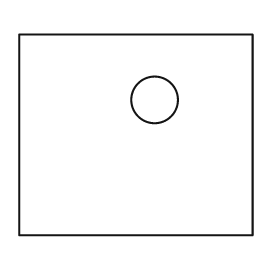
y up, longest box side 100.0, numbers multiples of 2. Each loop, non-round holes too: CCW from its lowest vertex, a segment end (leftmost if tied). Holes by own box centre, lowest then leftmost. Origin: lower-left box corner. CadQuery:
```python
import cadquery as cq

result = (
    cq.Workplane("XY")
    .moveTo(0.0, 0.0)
    .lineTo(100.0, 0.0)
    .lineTo(100.0, 86.0)
    .lineTo(0.0, 86.0)
    .close()
    .moveTo(58.0, 58.0)
    .circle(10.0)
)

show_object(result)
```